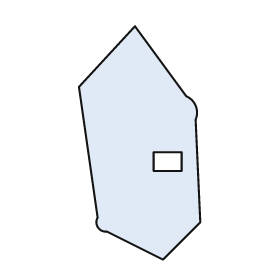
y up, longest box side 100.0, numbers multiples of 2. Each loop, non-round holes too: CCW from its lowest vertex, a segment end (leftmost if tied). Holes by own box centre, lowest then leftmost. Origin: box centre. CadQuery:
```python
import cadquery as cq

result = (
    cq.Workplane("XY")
    .moveTo(10.0, -50.0)
    .lineTo(26.0, -34.0)
    .lineTo(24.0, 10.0)
    .threePointArc((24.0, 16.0), (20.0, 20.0))
    .lineTo(-2.0, 50.0)
    .lineTo(-26.0, 24.0)
    .lineTo(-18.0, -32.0)
    .threePointArc((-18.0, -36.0), (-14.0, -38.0))
    .close()
    .moveTo(6.0, -12.0)
    .lineTo(18.0, -12.0)
    .lineTo(18.0, -4.0)
    .lineTo(6.0, -4.0)
    .close()
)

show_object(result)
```